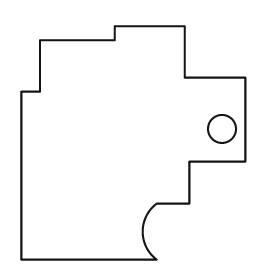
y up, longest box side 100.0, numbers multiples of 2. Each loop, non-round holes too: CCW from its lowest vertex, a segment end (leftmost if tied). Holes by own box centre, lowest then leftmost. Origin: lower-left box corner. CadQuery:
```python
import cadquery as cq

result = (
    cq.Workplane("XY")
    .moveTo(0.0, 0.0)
    .lineTo(58.0, 0.0)
    .threePointArc((52.0, 12.0), (58.0, 24.0))
    .lineTo(72.0, 24.0)
    .lineTo(72.0, 42.0)
    .lineTo(96.0, 42.0)
    .lineTo(96.0, 78.0)
    .lineTo(70.0, 78.0)
    .lineTo(70.0, 100.0)
    .lineTo(40.0, 100.0)
    .lineTo(40.0, 94.0)
    .lineTo(8.0, 94.0)
    .lineTo(8.0, 72.0)
    .lineTo(0.0, 72.0)
    .close()
    .moveTo(86.0, 56.0)
    .circle(6.0)
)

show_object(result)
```